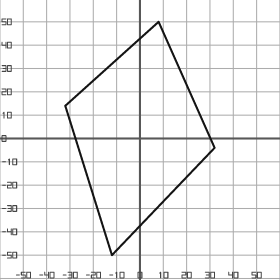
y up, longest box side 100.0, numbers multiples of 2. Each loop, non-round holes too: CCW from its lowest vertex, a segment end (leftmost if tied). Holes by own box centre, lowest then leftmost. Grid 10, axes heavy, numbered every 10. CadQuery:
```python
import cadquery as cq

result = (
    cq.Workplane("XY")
    .moveTo(-12.0, -50.0)
    .lineTo(32.0, -4.0)
    .lineTo(8.0, 50.0)
    .lineTo(-32.0, 14.0)
    .close()
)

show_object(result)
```